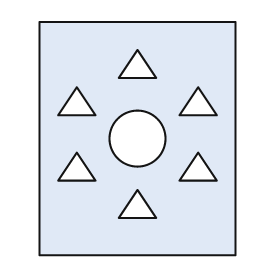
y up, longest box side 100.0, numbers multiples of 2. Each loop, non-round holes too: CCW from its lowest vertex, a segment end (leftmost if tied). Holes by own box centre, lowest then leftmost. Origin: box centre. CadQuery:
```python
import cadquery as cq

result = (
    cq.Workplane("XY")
    .moveTo(-42.0, -50.0)
    .lineTo(42.0, -50.0)
    .lineTo(42.0, 50.0)
    .lineTo(-42.0, 50.0)
    .close()
    .moveTo(-8.0, -34.0)
    .lineTo(8.0, -34.0)
    .lineTo(0.0, -22.0)
    .close()
    .moveTo(-34.0, -18.0)
    .lineTo(-18.0, -18.0)
    .lineTo(-26.0, -6.0)
    .close()
    .moveTo(18.0, -18.0)
    .lineTo(34.0, -18.0)
    .lineTo(26.0, -6.0)
    .close()
    .moveTo(0.0, 0.0)
    .circle(12.0)
    .moveTo(-34.0, 10.0)
    .lineTo(-18.0, 10.0)
    .lineTo(-26.0, 22.0)
    .close()
    .moveTo(18.0, 10.0)
    .lineTo(34.0, 10.0)
    .lineTo(26.0, 22.0)
    .close()
    .moveTo(-8.0, 26.0)
    .lineTo(8.0, 26.0)
    .lineTo(0.0, 38.0)
    .close()
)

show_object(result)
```